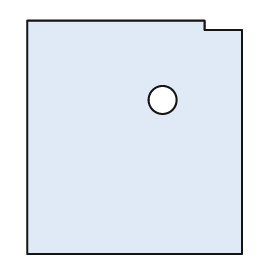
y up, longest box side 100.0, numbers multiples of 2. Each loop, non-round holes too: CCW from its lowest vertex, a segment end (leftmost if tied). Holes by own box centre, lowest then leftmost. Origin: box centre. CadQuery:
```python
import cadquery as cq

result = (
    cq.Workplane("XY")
    .moveTo(-46.0, -50.0)
    .lineTo(46.0, -50.0)
    .lineTo(46.0, 46.0)
    .lineTo(30.0, 46.0)
    .lineTo(30.0, 50.0)
    .lineTo(-46.0, 50.0)
    .close()
    .moveTo(12.0, 16.0)
    .circle(6.0)
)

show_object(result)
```